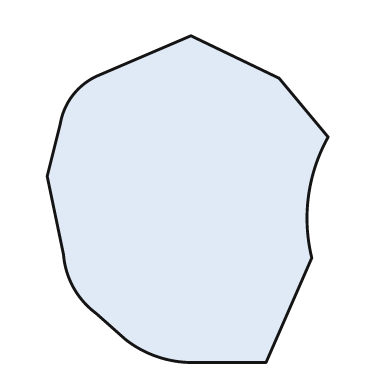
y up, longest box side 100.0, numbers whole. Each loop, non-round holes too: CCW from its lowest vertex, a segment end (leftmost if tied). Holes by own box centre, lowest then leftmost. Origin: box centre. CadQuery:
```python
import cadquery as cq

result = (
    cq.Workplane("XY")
    .moveTo(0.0, -50.0)
    .lineTo(24.0, -50.0)
    .lineTo(38.0, -18.0)
    .threePointArc((37.0, 1.0), (43.0, 19.0))
    .lineTo(28.0, 37.0)
    .lineTo(1.0, 50.0)
    .lineTo(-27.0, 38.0)
    .threePointArc((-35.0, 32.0), (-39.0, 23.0))
    .lineTo(-43.0, 7.0)
    .lineTo(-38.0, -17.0)
    .threePointArc((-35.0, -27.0), (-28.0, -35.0))
    .lineTo(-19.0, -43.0)
    .threePointArc((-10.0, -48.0), (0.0, -50.0))
    .close()
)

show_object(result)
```